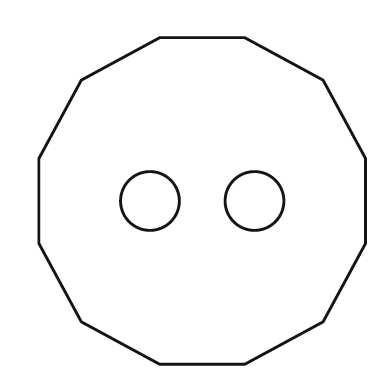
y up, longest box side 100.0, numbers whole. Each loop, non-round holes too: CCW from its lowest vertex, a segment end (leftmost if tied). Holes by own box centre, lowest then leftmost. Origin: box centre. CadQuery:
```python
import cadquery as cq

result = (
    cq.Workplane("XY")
    .moveTo(-13.0, -50.0)
    .lineTo(13.0, -50.0)
    .lineTo(37.0, -37.0)
    .lineTo(50.0, -13.0)
    .lineTo(50.0, 13.0)
    .lineTo(37.0, 37.0)
    .lineTo(13.0, 50.0)
    .lineTo(-13.0, 50.0)
    .lineTo(-37.0, 37.0)
    .lineTo(-50.0, 13.0)
    .lineTo(-50.0, -13.0)
    .lineTo(-37.0, -37.0)
    .close()
    .moveTo(-16.0, 0.0)
    .circle(9.0)
    .moveTo(16.0, 0.0)
    .circle(9.0)
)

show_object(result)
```